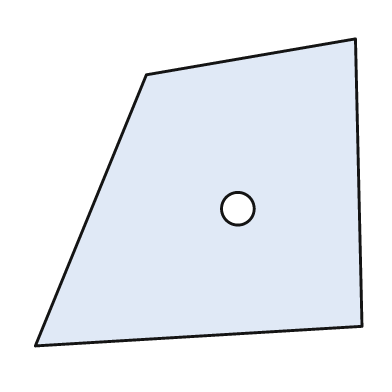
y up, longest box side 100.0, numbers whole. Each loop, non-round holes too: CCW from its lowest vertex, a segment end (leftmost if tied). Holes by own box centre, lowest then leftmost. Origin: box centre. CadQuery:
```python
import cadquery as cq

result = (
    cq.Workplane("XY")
    .moveTo(-50.0, -47.0)
    .lineTo(50.0, -41.0)
    .lineTo(48.0, 47.0)
    .lineTo(-16.0, 36.0)
    .close()
    .moveTo(12.0, -5.0)
    .circle(5.0)
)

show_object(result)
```